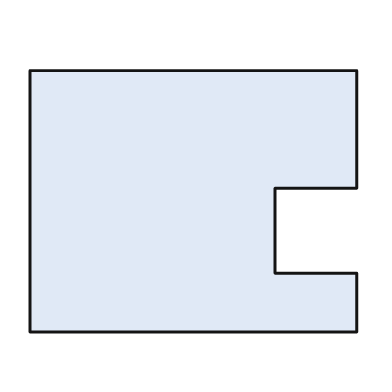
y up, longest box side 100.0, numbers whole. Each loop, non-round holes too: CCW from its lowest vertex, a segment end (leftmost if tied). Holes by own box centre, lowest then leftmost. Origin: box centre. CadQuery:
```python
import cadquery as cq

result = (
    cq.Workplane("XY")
    .moveTo(-50.0, -40.0)
    .lineTo(50.0, -40.0)
    .lineTo(50.0, -22.0)
    .lineTo(25.0, -22.0)
    .lineTo(25.0, 4.0)
    .lineTo(50.0, 4.0)
    .lineTo(50.0, 40.0)
    .lineTo(-50.0, 40.0)
    .close()
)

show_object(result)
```